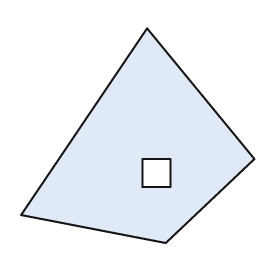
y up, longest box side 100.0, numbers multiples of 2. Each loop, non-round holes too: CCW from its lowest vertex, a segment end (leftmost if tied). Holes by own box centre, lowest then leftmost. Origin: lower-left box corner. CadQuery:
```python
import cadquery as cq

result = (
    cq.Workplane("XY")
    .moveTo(62.0, 0.0)
    .lineTo(100.0, 36.0)
    .lineTo(54.0, 92.0)
    .lineTo(0.0, 12.0)
    .close()
    .moveTo(52.0, 24.0)
    .lineTo(64.0, 24.0)
    .lineTo(64.0, 36.0)
    .lineTo(52.0, 36.0)
    .close()
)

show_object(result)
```